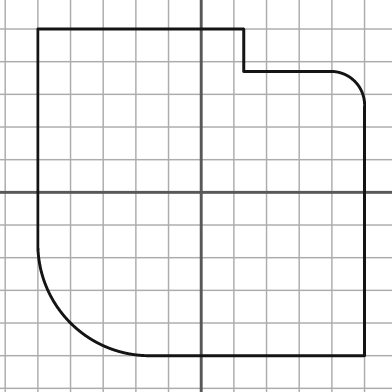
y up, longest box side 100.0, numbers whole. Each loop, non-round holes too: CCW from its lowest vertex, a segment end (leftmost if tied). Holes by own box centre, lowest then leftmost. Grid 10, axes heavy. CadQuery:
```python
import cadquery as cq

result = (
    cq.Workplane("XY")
    .moveTo(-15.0, -50.0)
    .lineTo(50.0, -50.0)
    .lineTo(50.0, 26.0)
    .threePointArc((47.0, 34.0), (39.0, 37.0))
    .lineTo(13.0, 37.0)
    .lineTo(13.0, 50.0)
    .lineTo(-50.0, 50.0)
    .lineTo(-50.0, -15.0)
    .threePointArc((-40.0, -40.0), (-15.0, -50.0))
    .close()
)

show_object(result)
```